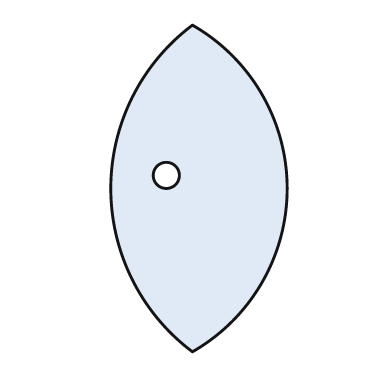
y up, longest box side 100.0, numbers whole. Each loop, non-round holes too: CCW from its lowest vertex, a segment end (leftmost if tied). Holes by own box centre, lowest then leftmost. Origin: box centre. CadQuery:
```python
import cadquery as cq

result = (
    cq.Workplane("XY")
    .moveTo(-2.0, -50.0)
    .threePointArc((27.0, 0.0), (-2.0, 50.0))
    .threePointArc((-27.0, 0.0), (-2.0, -50.0))
    .close()
    .moveTo(-10.0, 4.0)
    .circle(4.0)
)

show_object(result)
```